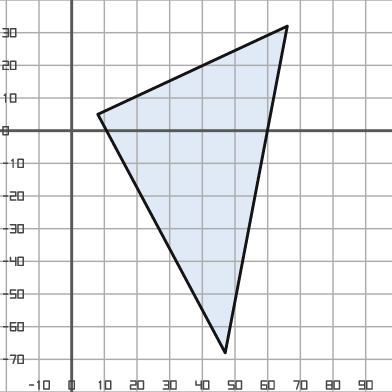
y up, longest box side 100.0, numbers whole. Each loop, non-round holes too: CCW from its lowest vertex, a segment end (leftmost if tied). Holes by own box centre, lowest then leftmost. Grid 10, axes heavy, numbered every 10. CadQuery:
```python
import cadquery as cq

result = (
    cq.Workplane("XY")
    .moveTo(47.0, -68.0)
    .lineTo(66.0, 32.0)
    .lineTo(8.0, 5.0)
    .close()
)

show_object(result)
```